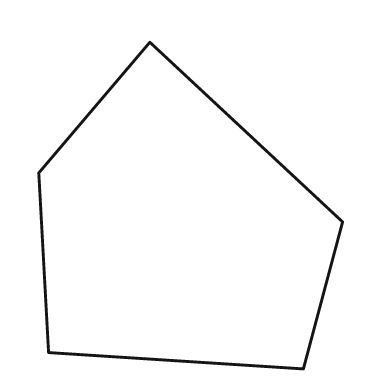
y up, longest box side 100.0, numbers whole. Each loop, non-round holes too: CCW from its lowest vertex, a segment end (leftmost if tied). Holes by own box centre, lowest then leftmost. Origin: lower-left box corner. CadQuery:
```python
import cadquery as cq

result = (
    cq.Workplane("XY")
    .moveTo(81.0, 0.0)
    .lineTo(93.0, 45.0)
    .lineTo(34.0, 100.0)
    .lineTo(0.0, 60.0)
    .lineTo(3.0, 5.0)
    .close()
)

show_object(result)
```